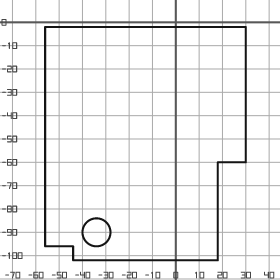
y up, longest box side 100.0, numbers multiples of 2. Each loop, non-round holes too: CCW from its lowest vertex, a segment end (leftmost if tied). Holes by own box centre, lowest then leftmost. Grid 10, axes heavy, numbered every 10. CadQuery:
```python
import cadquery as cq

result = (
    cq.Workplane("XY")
    .moveTo(-44.0, -102.0)
    .lineTo(18.0, -102.0)
    .lineTo(18.0, -60.0)
    .lineTo(30.0, -60.0)
    .lineTo(30.0, -2.0)
    .lineTo(-56.0, -2.0)
    .lineTo(-56.0, -96.0)
    .lineTo(-44.0, -96.0)
    .close()
    .moveTo(-34.0, -90.0)
    .circle(6.0)
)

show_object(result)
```